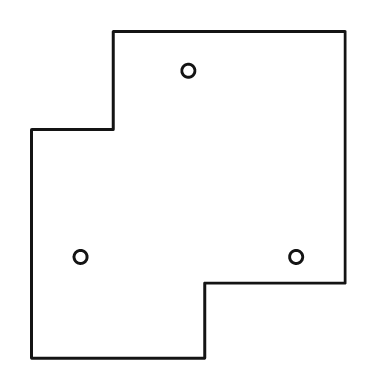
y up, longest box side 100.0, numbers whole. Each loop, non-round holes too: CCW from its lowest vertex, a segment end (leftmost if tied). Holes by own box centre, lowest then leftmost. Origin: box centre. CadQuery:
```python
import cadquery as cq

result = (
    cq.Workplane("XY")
    .moveTo(-48.0, -50.0)
    .lineTo(5.0, -50.0)
    .lineTo(5.0, -27.0)
    .lineTo(48.0, -27.0)
    .lineTo(48.0, 50.0)
    .lineTo(-23.0, 50.0)
    .lineTo(-23.0, 20.0)
    .lineTo(-48.0, 20.0)
    .close()
    .moveTo(-33.0, -19.0)
    .circle(2.0)
    .moveTo(33.0, -19.0)
    .circle(2.0)
    .moveTo(0.0, 38.0)
    .circle(2.0)
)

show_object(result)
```